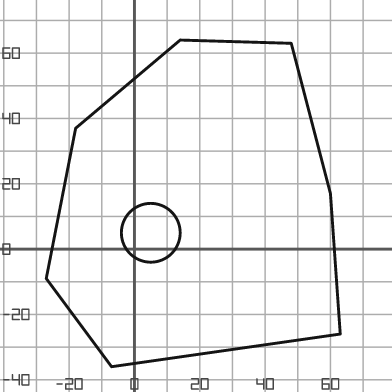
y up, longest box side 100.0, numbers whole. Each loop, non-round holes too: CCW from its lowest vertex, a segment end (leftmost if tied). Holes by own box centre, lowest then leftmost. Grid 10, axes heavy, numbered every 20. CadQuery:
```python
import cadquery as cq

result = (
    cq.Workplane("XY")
    .moveTo(-7.0, -36.0)
    .lineTo(63.0, -26.0)
    .lineTo(60.0, 17.0)
    .lineTo(48.0, 63.0)
    .lineTo(14.0, 64.0)
    .lineTo(-18.0, 37.0)
    .lineTo(-27.0, -9.0)
    .close()
    .moveTo(5.0, 5.0)
    .circle(9.0)
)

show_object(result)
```